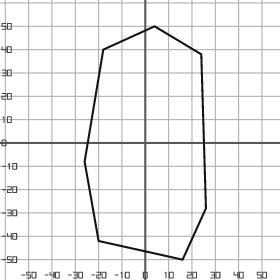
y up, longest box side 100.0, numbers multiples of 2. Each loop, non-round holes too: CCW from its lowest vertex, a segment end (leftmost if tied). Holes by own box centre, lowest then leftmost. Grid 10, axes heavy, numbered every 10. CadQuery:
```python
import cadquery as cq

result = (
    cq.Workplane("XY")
    .moveTo(16.0, -50.0)
    .lineTo(26.0, -28.0)
    .lineTo(24.0, 38.0)
    .lineTo(4.0, 50.0)
    .lineTo(-18.0, 40.0)
    .lineTo(-26.0, -8.0)
    .lineTo(-20.0, -42.0)
    .close()
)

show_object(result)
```